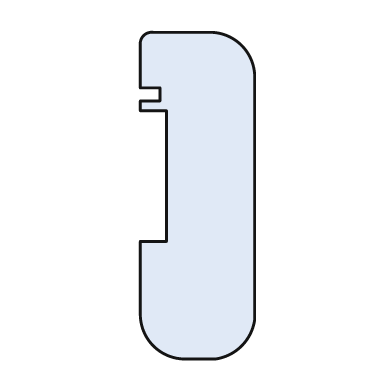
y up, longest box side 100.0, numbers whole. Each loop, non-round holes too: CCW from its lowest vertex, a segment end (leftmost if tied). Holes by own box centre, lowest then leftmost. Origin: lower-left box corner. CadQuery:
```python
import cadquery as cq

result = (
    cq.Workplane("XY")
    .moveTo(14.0, 0.0)
    .lineTo(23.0, 0.0)
    .threePointArc((31.0, 4.0), (35.0, 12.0))
    .lineTo(35.0, 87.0)
    .threePointArc((31.0, 96.0), (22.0, 100.0))
    .lineTo(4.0, 100.0)
    .threePointArc((1.0, 99.0), (0.0, 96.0))
    .lineTo(0.0, 83.0)
    .lineTo(6.0, 83.0)
    .lineTo(6.0, 79.0)
    .lineTo(0.0, 79.0)
    .lineTo(0.0, 76.0)
    .lineTo(8.0, 76.0)
    .lineTo(8.0, 36.0)
    .lineTo(0.0, 36.0)
    .lineTo(0.0, 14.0)
    .threePointArc((4.0, 4.0), (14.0, 0.0))
    .close()
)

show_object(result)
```